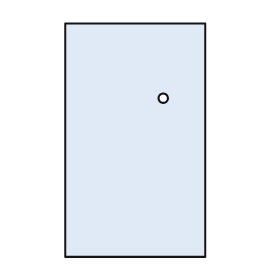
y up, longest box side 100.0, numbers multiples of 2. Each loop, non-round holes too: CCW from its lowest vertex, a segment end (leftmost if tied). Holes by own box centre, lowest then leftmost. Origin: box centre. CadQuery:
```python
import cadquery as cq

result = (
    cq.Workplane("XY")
    .moveTo(-30.0, -50.0)
    .lineTo(30.0, -50.0)
    .lineTo(30.0, 50.0)
    .lineTo(-30.0, 50.0)
    .close()
    .moveTo(12.0, 18.0)
    .circle(2.0)
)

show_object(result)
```